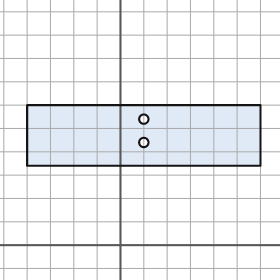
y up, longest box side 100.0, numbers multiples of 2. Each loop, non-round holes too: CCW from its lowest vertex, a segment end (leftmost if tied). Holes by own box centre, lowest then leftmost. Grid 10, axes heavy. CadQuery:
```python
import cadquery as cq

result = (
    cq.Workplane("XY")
    .moveTo(-40.0, 34.0)
    .lineTo(60.0, 34.0)
    .lineTo(60.0, 60.0)
    .lineTo(-40.0, 60.0)
    .close()
    .moveTo(10.0, 44.0)
    .circle(2.0)
    .moveTo(10.0, 54.0)
    .circle(2.0)
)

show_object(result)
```